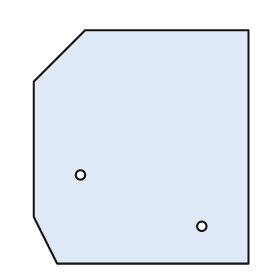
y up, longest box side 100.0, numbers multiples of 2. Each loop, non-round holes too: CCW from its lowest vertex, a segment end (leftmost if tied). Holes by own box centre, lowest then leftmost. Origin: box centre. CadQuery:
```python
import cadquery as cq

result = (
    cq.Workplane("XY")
    .moveTo(-36.0, -50.0)
    .lineTo(46.0, -50.0)
    .lineTo(46.0, 50.0)
    .lineTo(-24.0, 50.0)
    .lineTo(-46.0, 28.0)
    .lineTo(-46.0, -30.0)
    .close()
    .moveTo(26.0, -34.0)
    .circle(2.0)
    .moveTo(-26.0, -12.0)
    .circle(2.0)
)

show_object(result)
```